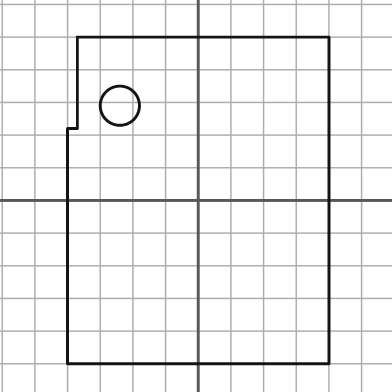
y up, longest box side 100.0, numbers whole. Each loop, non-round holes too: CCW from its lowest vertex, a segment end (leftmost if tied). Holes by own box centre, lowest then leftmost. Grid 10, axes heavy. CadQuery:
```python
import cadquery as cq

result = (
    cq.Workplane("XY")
    .moveTo(-40.0, -50.0)
    .lineTo(40.0, -50.0)
    .lineTo(40.0, 50.0)
    .lineTo(-37.0, 50.0)
    .lineTo(-37.0, 22.0)
    .lineTo(-40.0, 22.0)
    .close()
    .moveTo(-24.0, 29.0)
    .circle(6.0)
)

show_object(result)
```